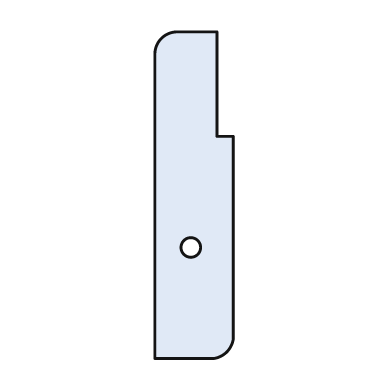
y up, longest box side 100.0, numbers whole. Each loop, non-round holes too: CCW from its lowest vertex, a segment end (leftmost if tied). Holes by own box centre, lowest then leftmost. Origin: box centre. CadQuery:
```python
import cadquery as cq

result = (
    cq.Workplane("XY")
    .moveTo(-12.0, -50.0)
    .lineTo(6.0, -50.0)
    .threePointArc((10.0, -48.0), (12.0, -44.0))
    .lineTo(12.0, 18.0)
    .lineTo(7.0, 18.0)
    .lineTo(7.0, 50.0)
    .lineTo(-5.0, 50.0)
    .threePointArc((-10.0, 48.0), (-12.0, 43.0))
    .close()
    .moveTo(-1.0, -16.0)
    .circle(3.0)
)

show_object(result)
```